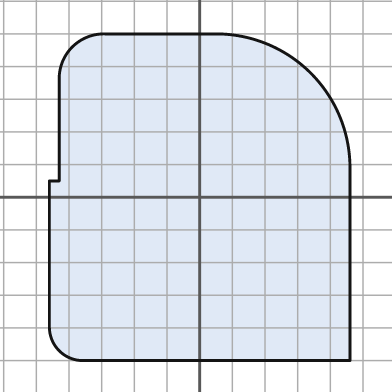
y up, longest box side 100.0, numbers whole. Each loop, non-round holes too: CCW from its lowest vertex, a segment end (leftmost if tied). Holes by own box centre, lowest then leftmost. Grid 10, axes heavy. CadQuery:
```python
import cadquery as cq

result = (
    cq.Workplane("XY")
    .moveTo(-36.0, -50.0)
    .lineTo(46.0, -50.0)
    .lineTo(46.0, 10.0)
    .threePointArc((34.0, 38.0), (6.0, 50.0))
    .lineTo(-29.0, 50.0)
    .threePointArc((-39.0, 46.0), (-43.0, 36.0))
    .lineTo(-43.0, 5.0)
    .lineTo(-46.0, 5.0)
    .lineTo(-46.0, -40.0)
    .threePointArc((-43.0, -47.0), (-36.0, -50.0))
    .close()
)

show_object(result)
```